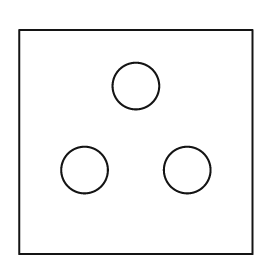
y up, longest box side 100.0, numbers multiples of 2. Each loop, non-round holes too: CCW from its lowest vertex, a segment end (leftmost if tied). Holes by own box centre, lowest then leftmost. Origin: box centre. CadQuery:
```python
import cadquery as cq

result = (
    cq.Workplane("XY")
    .moveTo(-50.0, -48.0)
    .lineTo(50.0, -48.0)
    .lineTo(50.0, 48.0)
    .lineTo(-50.0, 48.0)
    .close()
    .moveTo(-22.0, -12.0)
    .circle(10.0)
    .moveTo(22.0, -12.0)
    .circle(10.0)
    .moveTo(0.0, 24.0)
    .circle(10.0)
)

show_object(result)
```